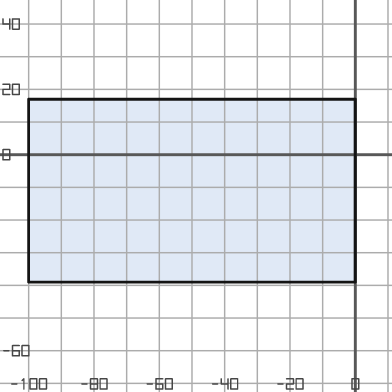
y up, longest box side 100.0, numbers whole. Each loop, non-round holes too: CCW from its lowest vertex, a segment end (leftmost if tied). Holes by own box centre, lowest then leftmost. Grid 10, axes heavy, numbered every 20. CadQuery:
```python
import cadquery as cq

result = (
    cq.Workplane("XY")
    .moveTo(-100.0, -39.0)
    .lineTo(0.0, -39.0)
    .lineTo(0.0, 17.0)
    .lineTo(-100.0, 17.0)
    .close()
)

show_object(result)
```